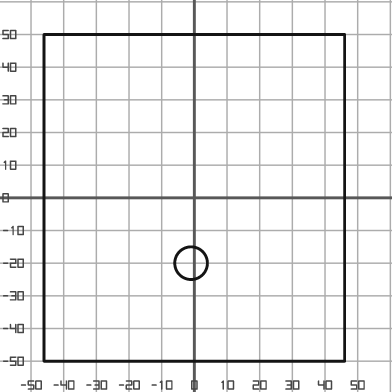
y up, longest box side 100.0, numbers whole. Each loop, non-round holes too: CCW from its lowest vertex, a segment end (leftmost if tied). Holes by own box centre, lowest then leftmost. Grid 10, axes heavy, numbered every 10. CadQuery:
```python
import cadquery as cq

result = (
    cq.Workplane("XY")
    .moveTo(-46.0, -50.0)
    .lineTo(46.0, -50.0)
    .lineTo(46.0, 50.0)
    .lineTo(-46.0, 50.0)
    .close()
    .moveTo(-1.0, -20.0)
    .circle(5.0)
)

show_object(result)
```